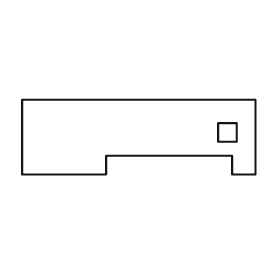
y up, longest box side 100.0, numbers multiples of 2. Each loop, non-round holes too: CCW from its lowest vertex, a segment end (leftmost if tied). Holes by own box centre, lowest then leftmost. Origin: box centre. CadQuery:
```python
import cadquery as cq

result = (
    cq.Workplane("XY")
    .moveTo(-50.0, -16.0)
    .lineTo(-14.0, -16.0)
    .lineTo(-14.0, -8.0)
    .lineTo(40.0, -8.0)
    .lineTo(40.0, -16.0)
    .lineTo(50.0, -16.0)
    .lineTo(50.0, 16.0)
    .lineTo(-50.0, 16.0)
    .close()
    .moveTo(34.0, -2.0)
    .lineTo(42.0, -2.0)
    .lineTo(42.0, 6.0)
    .lineTo(34.0, 6.0)
    .close()
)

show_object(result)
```